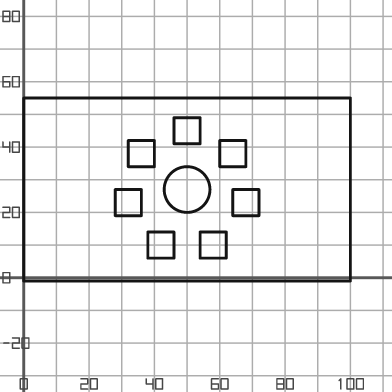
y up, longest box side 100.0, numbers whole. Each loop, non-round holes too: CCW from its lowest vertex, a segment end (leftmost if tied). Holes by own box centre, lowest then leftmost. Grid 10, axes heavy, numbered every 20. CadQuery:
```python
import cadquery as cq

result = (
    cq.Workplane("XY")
    .moveTo(0.0, -1.0)
    .lineTo(100.0, -1.0)
    .lineTo(100.0, 55.0)
    .lineTo(0.0, 55.0)
    .close()
    .moveTo(38.0, 6.0)
    .lineTo(46.0, 6.0)
    .lineTo(46.0, 14.0)
    .lineTo(38.0, 14.0)
    .close()
    .moveTo(54.0, 6.0)
    .lineTo(62.0, 6.0)
    .lineTo(62.0, 14.0)
    .lineTo(54.0, 14.0)
    .close()
    .moveTo(28.0, 19.0)
    .lineTo(36.0, 19.0)
    .lineTo(36.0, 27.0)
    .lineTo(28.0, 27.0)
    .close()
    .moveTo(64.0, 19.0)
    .lineTo(72.0, 19.0)
    .lineTo(72.0, 27.0)
    .lineTo(64.0, 27.0)
    .close()
    .moveTo(50.0, 27.0)
    .circle(7.0)
    .moveTo(32.0, 34.0)
    .lineTo(40.0, 34.0)
    .lineTo(40.0, 42.0)
    .lineTo(32.0, 42.0)
    .close()
    .moveTo(60.0, 34.0)
    .lineTo(68.0, 34.0)
    .lineTo(68.0, 42.0)
    .lineTo(60.0, 42.0)
    .close()
    .moveTo(46.0, 41.0)
    .lineTo(54.0, 41.0)
    .lineTo(54.0, 49.0)
    .lineTo(46.0, 49.0)
    .close()
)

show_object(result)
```